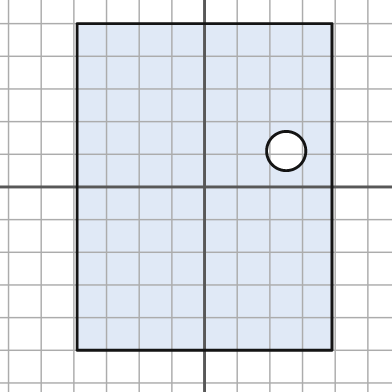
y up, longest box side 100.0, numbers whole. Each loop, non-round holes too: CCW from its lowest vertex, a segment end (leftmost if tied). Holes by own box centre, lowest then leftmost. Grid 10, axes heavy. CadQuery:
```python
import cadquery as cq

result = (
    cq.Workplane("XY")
    .moveTo(-39.0, -50.0)
    .lineTo(39.0, -50.0)
    .lineTo(39.0, 50.0)
    .lineTo(-39.0, 50.0)
    .close()
    .moveTo(25.0, 11.0)
    .circle(6.0)
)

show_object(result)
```